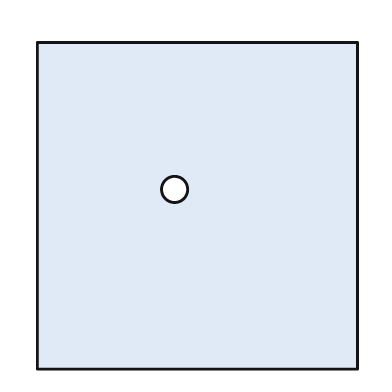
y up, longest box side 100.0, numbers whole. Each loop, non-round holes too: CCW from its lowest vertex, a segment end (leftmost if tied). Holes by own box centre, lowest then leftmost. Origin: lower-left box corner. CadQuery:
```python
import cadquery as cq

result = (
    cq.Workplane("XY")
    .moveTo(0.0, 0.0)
    .lineTo(98.0, 0.0)
    .lineTo(98.0, 100.0)
    .lineTo(0.0, 100.0)
    .close()
    .moveTo(42.0, 55.0)
    .circle(4.0)
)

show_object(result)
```